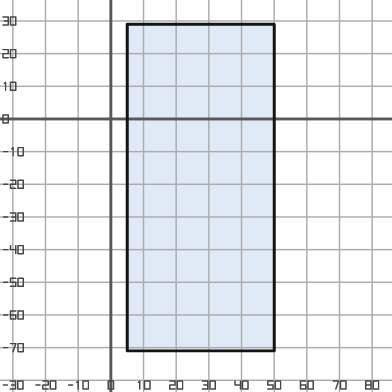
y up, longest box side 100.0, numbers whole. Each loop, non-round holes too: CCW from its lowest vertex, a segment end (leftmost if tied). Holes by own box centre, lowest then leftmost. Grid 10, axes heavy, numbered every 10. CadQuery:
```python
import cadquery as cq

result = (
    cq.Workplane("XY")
    .moveTo(5.0, -71.0)
    .lineTo(50.0, -71.0)
    .lineTo(50.0, 29.0)
    .lineTo(5.0, 29.0)
    .close()
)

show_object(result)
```